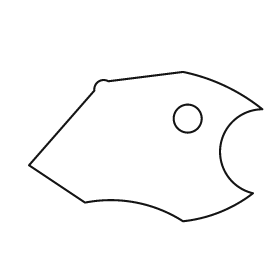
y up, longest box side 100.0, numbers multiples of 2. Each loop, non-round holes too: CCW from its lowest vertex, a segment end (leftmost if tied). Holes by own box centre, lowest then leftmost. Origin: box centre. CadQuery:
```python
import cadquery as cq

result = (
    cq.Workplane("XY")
    .moveTo(16.0, -32.0)
    .threePointArc((32.0, -28.0), (46.0, -20.0))
    .threePointArc((32.0, 0.0), (50.0, 16.0))
    .threePointArc((34.0, 26.0), (16.0, 32.0))
    .lineTo(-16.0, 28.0)
    .threePointArc((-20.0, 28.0), (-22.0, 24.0))
    .lineTo(-50.0, -8.0)
    .lineTo(-26.0, -24.0)
    .threePointArc((-4.0, -24.0), (16.0, -32.0))
    .close()
    .moveTo(18.0, 12.0)
    .circle(6.0)
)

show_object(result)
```